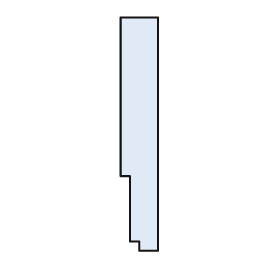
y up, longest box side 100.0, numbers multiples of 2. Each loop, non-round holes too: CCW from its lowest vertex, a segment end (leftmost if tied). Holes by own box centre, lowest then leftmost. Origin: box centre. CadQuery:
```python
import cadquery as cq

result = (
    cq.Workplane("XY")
    .moveTo(0.0, -50.0)
    .lineTo(8.0, -50.0)
    .lineTo(8.0, 50.0)
    .lineTo(-8.0, 50.0)
    .lineTo(-8.0, -18.0)
    .lineTo(-4.0, -18.0)
    .lineTo(-4.0, -46.0)
    .lineTo(0.0, -46.0)
    .close()
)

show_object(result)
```